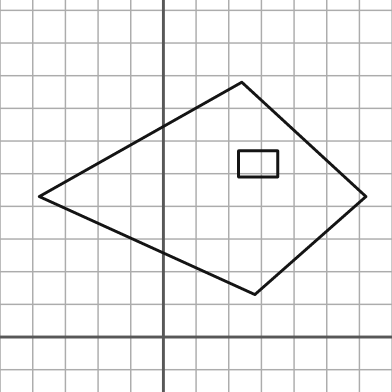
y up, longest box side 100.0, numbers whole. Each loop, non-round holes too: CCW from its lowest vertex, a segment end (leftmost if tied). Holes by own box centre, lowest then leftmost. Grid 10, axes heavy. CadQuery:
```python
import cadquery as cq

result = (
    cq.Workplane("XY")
    .moveTo(28.0, 13.0)
    .lineTo(62.0, 43.0)
    .lineTo(24.0, 78.0)
    .lineTo(-38.0, 43.0)
    .close()
    .moveTo(23.0, 49.0)
    .lineTo(35.0, 49.0)
    .lineTo(35.0, 57.0)
    .lineTo(23.0, 57.0)
    .close()
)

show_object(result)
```